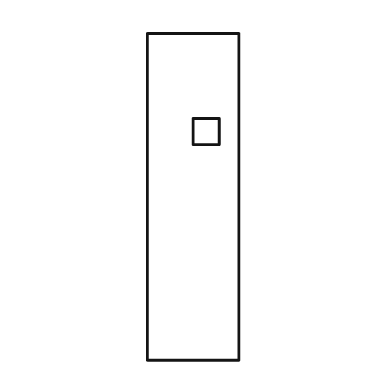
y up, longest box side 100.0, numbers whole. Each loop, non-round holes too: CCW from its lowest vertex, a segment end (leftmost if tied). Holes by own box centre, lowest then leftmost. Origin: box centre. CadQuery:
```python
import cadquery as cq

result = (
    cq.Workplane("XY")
    .moveTo(-14.0, -50.0)
    .lineTo(14.0, -50.0)
    .lineTo(14.0, 50.0)
    .lineTo(-14.0, 50.0)
    .close()
    .moveTo(0.0, 16.0)
    .lineTo(8.0, 16.0)
    .lineTo(8.0, 24.0)
    .lineTo(0.0, 24.0)
    .close()
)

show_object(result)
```